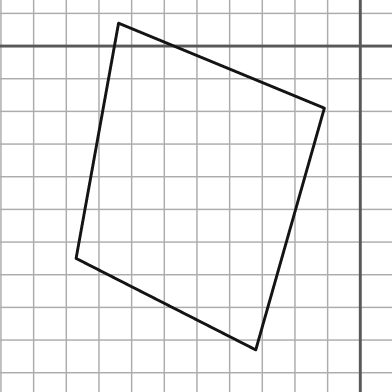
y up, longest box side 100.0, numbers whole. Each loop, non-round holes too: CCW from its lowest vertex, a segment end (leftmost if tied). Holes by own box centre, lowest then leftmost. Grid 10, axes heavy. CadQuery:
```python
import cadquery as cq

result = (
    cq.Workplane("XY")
    .moveTo(-32.0, -93.0)
    .lineTo(-11.0, -19.0)
    .lineTo(-74.0, 7.0)
    .lineTo(-87.0, -65.0)
    .close()
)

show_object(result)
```